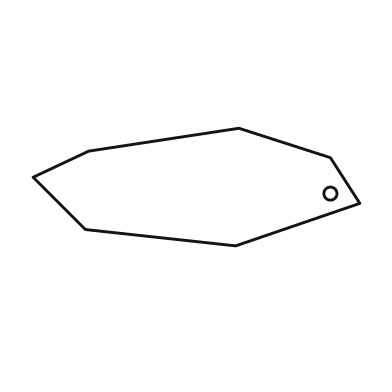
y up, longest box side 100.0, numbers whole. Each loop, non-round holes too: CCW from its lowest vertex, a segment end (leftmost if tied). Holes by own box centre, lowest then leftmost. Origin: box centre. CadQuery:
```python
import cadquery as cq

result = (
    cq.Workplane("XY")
    .moveTo(12.0, -18.0)
    .lineTo(50.0, -5.0)
    .lineTo(41.0, 9.0)
    .lineTo(13.0, 18.0)
    .lineTo(-33.0, 11.0)
    .lineTo(-50.0, 3.0)
    .lineTo(-34.0, -13.0)
    .close()
    .moveTo(41.0, -2.0)
    .circle(2.0)
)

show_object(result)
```